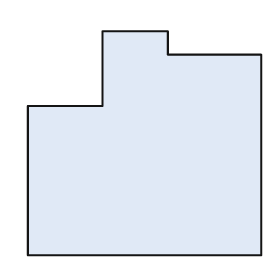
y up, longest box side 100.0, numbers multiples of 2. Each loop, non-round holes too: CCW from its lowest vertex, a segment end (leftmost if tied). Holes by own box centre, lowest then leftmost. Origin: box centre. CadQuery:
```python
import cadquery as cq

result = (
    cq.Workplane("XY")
    .moveTo(-50.0, -48.0)
    .lineTo(50.0, -48.0)
    .lineTo(50.0, 38.0)
    .lineTo(10.0, 38.0)
    .lineTo(10.0, 48.0)
    .lineTo(-18.0, 48.0)
    .lineTo(-18.0, 16.0)
    .lineTo(-50.0, 16.0)
    .close()
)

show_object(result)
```